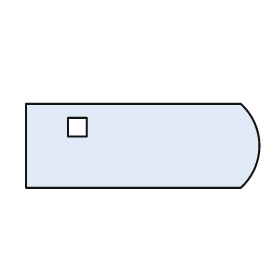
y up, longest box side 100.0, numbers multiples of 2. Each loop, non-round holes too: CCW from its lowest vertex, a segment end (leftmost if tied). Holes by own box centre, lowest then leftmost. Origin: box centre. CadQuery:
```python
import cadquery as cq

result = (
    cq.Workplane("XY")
    .moveTo(-50.0, -18.0)
    .lineTo(42.0, -18.0)
    .threePointArc((50.0, 0.0), (42.0, 18.0))
    .lineTo(-50.0, 18.0)
    .close()
    .moveTo(-32.0, 4.0)
    .lineTo(-24.0, 4.0)
    .lineTo(-24.0, 12.0)
    .lineTo(-32.0, 12.0)
    .close()
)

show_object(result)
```